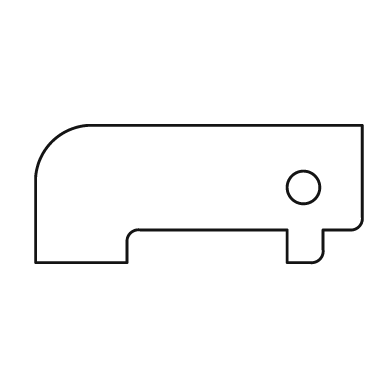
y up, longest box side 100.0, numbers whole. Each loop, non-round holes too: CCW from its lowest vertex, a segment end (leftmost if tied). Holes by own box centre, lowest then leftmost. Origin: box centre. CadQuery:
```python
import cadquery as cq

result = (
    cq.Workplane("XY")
    .moveTo(-50.0, -21.0)
    .lineTo(-22.0, -21.0)
    .lineTo(-22.0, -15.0)
    .threePointArc((-21.0, -12.0), (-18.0, -11.0))
    .lineTo(27.0, -11.0)
    .lineTo(27.0, -21.0)
    .lineTo(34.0, -21.0)
    .threePointArc((37.0, -20.0), (38.0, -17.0))
    .lineTo(38.0, -11.0)
    .lineTo(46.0, -11.0)
    .threePointArc((49.0, -10.0), (50.0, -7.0))
    .lineTo(50.0, 21.0)
    .lineTo(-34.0, 21.0)
    .threePointArc((-45.0, 16.0), (-50.0, 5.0))
    .close()
    .moveTo(32.0, 2.0)
    .circle(5.0)
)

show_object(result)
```